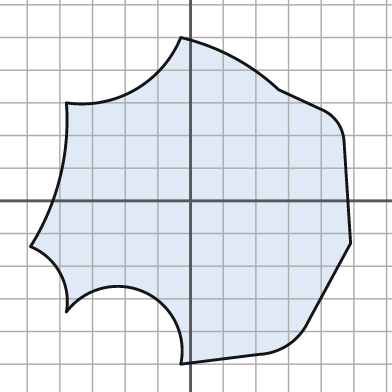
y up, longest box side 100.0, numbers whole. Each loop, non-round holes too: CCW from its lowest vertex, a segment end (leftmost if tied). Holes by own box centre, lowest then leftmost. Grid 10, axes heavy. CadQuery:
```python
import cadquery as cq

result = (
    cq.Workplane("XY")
    .moveTo(-3.0, -50.0)
    .lineTo(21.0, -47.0)
    .threePointArc((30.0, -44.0), (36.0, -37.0))
    .lineTo(49.0, -13.0)
    .lineTo(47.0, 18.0)
    .threePointArc((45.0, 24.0), (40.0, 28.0))
    .lineTo(27.0, 34.0)
    .threePointArc((13.0, 44.0), (-3.0, 50.0))
    .threePointArc((-17.0, 34.0), (-38.0, 30.0))
    .threePointArc((-40.0, 7.0), (-49.0, -14.0))
    .threePointArc((-40.0, -22.0), (-38.0, -34.0))
    .threePointArc((-14.0, -28.0), (-3.0, -50.0))
    .close()
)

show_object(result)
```